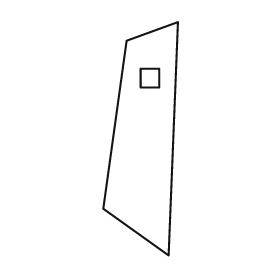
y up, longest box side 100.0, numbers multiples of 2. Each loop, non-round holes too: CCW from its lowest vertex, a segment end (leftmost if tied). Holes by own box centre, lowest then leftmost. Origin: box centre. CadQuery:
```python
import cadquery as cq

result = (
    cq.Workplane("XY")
    .moveTo(12.0, -50.0)
    .lineTo(16.0, 50.0)
    .lineTo(-6.0, 42.0)
    .lineTo(-16.0, -30.0)
    .close()
    .moveTo(0.0, 22.0)
    .lineTo(8.0, 22.0)
    .lineTo(8.0, 30.0)
    .lineTo(0.0, 30.0)
    .close()
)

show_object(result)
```